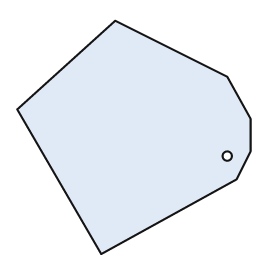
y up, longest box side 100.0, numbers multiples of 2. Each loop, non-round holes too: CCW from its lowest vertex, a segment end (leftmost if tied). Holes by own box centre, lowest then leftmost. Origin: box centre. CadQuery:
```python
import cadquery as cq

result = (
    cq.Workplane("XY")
    .moveTo(-14.0, -50.0)
    .lineTo(44.0, -18.0)
    .lineTo(50.0, -6.0)
    .lineTo(50.0, 8.0)
    .lineTo(40.0, 26.0)
    .lineTo(-8.0, 50.0)
    .lineTo(-50.0, 12.0)
    .close()
    .moveTo(40.0, -8.0)
    .circle(2.0)
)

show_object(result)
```